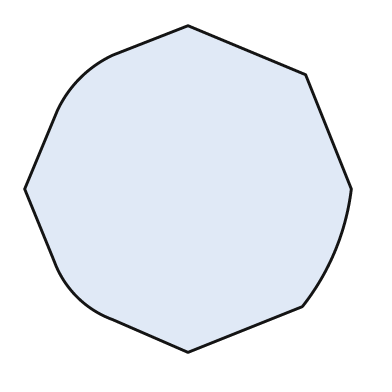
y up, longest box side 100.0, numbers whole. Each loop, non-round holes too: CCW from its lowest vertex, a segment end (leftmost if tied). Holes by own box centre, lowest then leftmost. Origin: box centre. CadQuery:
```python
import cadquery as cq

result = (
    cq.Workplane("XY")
    .moveTo(0.0, -50.0)
    .lineTo(35.0, -36.0)
    .threePointArc((45.0, -19.0), (50.0, 0.0))
    .lineTo(36.0, 35.0)
    .lineTo(0.0, 50.0)
    .lineTo(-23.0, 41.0)
    .threePointArc((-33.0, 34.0), (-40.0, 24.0))
    .lineTo(-50.0, 0.0)
    .lineTo(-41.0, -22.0)
    .threePointArc((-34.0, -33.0), (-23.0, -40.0))
    .close()
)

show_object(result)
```